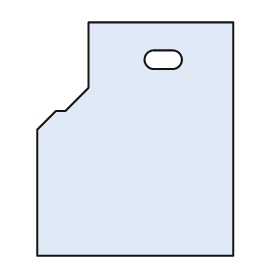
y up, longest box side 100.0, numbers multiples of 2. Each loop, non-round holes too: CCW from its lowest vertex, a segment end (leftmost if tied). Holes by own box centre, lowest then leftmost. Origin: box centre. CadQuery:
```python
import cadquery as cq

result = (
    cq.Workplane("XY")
    .moveTo(-42.0, -50.0)
    .lineTo(42.0, -50.0)
    .lineTo(42.0, 50.0)
    .lineTo(-20.0, 50.0)
    .lineTo(-20.0, 22.0)
    .lineTo(-30.0, 12.0)
    .lineTo(-34.0, 12.0)
    .lineTo(-42.0, 4.0)
    .close()
    .moveTo(8.0, 30.0)
    .lineTo(16.0, 30.0)
    .threePointArc((20.0, 34.0), (16.0, 38.0))
    .lineTo(8.0, 38.0)
    .threePointArc((4.0, 34.0), (8.0, 30.0))
    .close()
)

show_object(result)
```